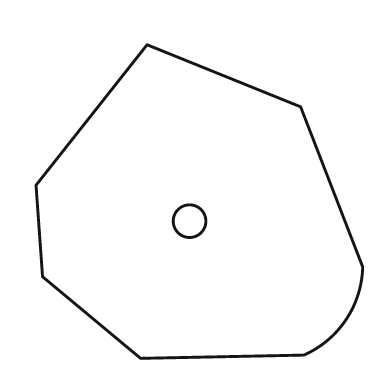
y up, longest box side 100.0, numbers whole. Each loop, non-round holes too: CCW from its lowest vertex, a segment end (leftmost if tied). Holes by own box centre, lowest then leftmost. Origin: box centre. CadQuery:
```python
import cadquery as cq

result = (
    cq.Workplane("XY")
    .moveTo(-18.0, -48.0)
    .lineTo(32.0, -47.0)
    .threePointArc((45.0, -36.0), (50.0, -20.0))
    .lineTo(31.0, 29.0)
    .lineTo(-16.0, 48.0)
    .lineTo(-50.0, 5.0)
    .lineTo(-48.0, -23.0)
    .close()
    .moveTo(-3.0, -6.0)
    .circle(5.0)
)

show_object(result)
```